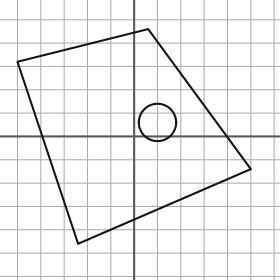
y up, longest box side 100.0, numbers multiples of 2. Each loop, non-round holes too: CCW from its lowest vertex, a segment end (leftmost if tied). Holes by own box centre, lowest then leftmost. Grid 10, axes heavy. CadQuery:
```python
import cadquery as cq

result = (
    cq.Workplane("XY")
    .moveTo(-24.0, -46.0)
    .lineTo(50.0, -14.0)
    .lineTo(6.0, 46.0)
    .lineTo(-50.0, 32.0)
    .close()
    .moveTo(10.0, 6.0)
    .circle(8.0)
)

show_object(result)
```